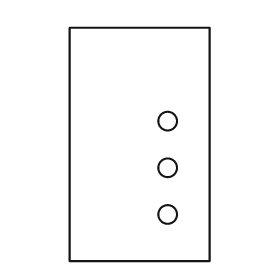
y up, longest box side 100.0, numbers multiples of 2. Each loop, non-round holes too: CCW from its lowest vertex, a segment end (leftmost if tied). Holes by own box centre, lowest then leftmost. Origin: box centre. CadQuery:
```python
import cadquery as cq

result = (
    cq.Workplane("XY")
    .moveTo(-30.0, -50.0)
    .lineTo(30.0, -50.0)
    .lineTo(30.0, 50.0)
    .lineTo(-30.0, 50.0)
    .close()
    .moveTo(12.0, -30.0)
    .circle(4.0)
    .moveTo(12.0, -10.0)
    .circle(4.0)
    .moveTo(12.0, 10.0)
    .circle(4.0)
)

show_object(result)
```